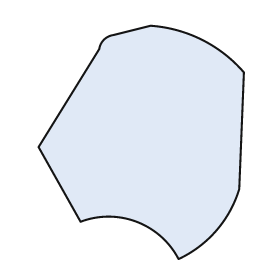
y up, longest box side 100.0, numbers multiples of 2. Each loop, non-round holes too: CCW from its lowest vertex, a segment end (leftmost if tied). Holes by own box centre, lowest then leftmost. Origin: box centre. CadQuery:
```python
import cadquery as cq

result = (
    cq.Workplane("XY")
    .moveTo(16.0, -50.0)
    .threePointArc((32.0, -38.0), (42.0, -20.0))
    .lineTo(44.0, 30.0)
    .threePointArc((26.0, 44.0), (4.0, 50.0))
    .lineTo(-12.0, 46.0)
    .threePointArc((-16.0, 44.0), (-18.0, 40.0))
    .lineTo(-44.0, -2.0)
    .lineTo(-26.0, -34.0)
    .threePointArc((-2.0, -34.0), (16.0, -50.0))
    .close()
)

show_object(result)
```